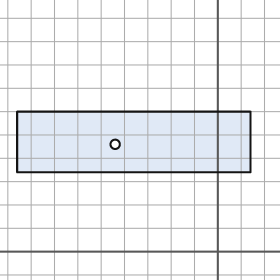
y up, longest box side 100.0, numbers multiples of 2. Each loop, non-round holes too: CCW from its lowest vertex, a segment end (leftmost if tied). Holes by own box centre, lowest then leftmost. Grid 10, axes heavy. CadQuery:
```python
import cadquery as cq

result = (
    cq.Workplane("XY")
    .moveTo(-86.0, 34.0)
    .lineTo(14.0, 34.0)
    .lineTo(14.0, 60.0)
    .lineTo(-86.0, 60.0)
    .close()
    .moveTo(-44.0, 46.0)
    .circle(2.0)
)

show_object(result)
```